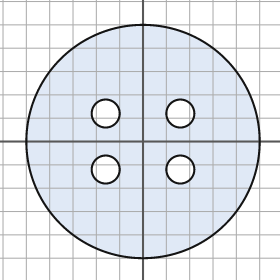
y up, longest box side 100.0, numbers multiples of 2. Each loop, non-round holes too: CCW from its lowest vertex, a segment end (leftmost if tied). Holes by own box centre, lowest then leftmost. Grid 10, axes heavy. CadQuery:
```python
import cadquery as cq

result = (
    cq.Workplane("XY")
    .moveTo(0.0, 0.0)
    .circle(50.0)
    .moveTo(-16.0, -12.0)
    .circle(6.0)
    .moveTo(16.0, -12.0)
    .circle(6.0)
    .moveTo(-16.0, 12.0)
    .circle(6.0)
    .moveTo(16.0, 12.0)
    .circle(6.0)
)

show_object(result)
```